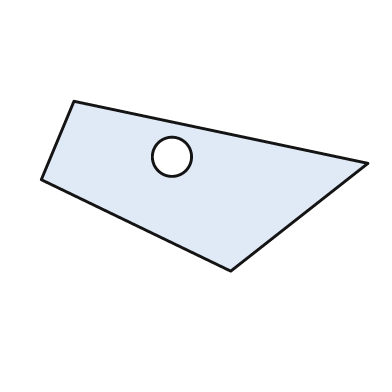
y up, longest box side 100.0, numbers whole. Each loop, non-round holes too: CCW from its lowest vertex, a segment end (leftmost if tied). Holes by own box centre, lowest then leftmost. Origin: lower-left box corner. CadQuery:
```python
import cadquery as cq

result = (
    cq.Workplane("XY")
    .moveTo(58.0, 0.0)
    .lineTo(100.0, 33.0)
    .lineTo(10.0, 52.0)
    .lineTo(0.0, 28.0)
    .close()
    .moveTo(40.0, 35.0)
    .circle(6.0)
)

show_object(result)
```